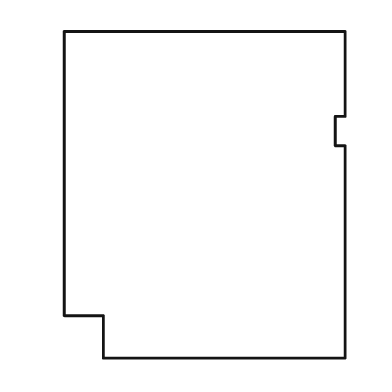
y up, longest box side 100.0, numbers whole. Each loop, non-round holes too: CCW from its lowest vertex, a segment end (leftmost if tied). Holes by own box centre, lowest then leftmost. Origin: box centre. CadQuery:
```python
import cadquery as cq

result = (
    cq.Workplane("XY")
    .moveTo(-31.0, -50.0)
    .lineTo(43.0, -50.0)
    .lineTo(43.0, 15.0)
    .lineTo(40.0, 15.0)
    .lineTo(40.0, 24.0)
    .lineTo(43.0, 24.0)
    .lineTo(43.0, 50.0)
    .lineTo(-43.0, 50.0)
    .lineTo(-43.0, -37.0)
    .lineTo(-31.0, -37.0)
    .close()
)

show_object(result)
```